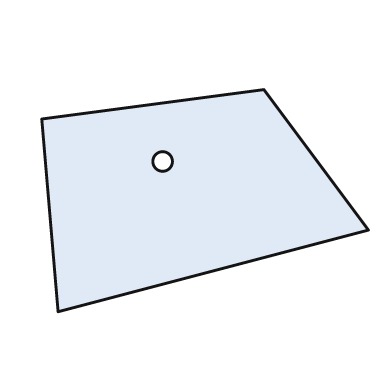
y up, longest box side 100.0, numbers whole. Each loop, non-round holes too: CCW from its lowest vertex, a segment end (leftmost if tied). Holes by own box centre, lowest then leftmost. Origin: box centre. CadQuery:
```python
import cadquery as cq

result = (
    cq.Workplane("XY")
    .moveTo(-45.0, -34.0)
    .lineTo(50.0, -9.0)
    .lineTo(18.0, 34.0)
    .lineTo(-50.0, 25.0)
    .close()
    .moveTo(-13.0, 12.0)
    .circle(3.0)
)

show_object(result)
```